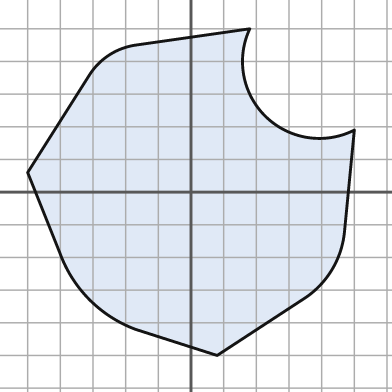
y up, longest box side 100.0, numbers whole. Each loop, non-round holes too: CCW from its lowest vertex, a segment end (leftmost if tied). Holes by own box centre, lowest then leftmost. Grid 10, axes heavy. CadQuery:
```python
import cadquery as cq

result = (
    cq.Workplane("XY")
    .moveTo(8.0, -50.0)
    .lineTo(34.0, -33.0)
    .threePointArc((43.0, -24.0), (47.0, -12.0))
    .lineTo(50.0, 19.0)
    .threePointArc((23.0, 23.0), (18.0, 50.0))
    .lineTo(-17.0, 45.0)
    .threePointArc((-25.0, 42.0), (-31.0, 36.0))
    .lineTo(-50.0, 6.0)
    .lineTo(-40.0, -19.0)
    .threePointArc((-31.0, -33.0), (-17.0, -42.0))
    .close()
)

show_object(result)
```